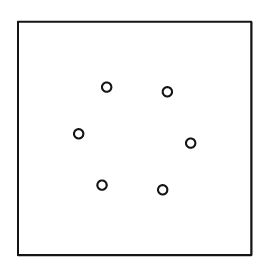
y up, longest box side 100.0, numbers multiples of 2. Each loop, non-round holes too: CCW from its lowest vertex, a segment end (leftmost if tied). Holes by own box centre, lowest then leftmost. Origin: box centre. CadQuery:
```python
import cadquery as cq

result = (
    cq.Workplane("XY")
    .moveTo(-50.0, -50.0)
    .lineTo(50.0, -50.0)
    .lineTo(50.0, 50.0)
    .lineTo(-50.0, 50.0)
    .close()
    .moveTo(12.0, -22.0)
    .circle(2.0)
    .moveTo(-14.0, -20.0)
    .circle(2.0)
    .moveTo(24.0, -2.0)
    .circle(2.0)
    .moveTo(-24.0, 2.0)
    .circle(2.0)
    .moveTo(14.0, 20.0)
    .circle(2.0)
    .moveTo(-12.0, 22.0)
    .circle(2.0)
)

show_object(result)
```